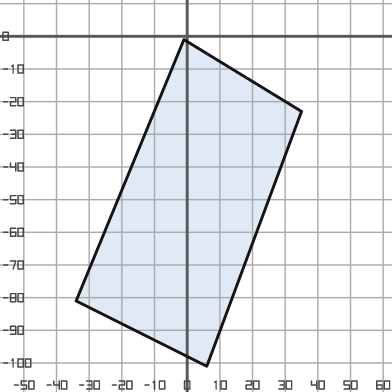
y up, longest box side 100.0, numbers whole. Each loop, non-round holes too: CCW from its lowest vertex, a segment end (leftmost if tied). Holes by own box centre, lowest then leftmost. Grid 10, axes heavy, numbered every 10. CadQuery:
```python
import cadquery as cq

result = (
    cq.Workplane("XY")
    .moveTo(6.0, -101.0)
    .lineTo(35.0, -23.0)
    .lineTo(-1.0, -1.0)
    .lineTo(-34.0, -81.0)
    .close()
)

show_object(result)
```